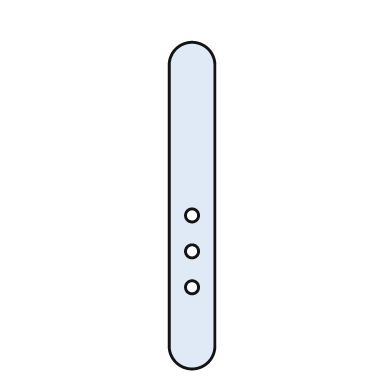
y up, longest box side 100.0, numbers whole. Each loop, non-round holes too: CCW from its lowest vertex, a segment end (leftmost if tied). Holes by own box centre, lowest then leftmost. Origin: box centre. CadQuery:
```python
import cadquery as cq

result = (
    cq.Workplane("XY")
    .moveTo(-7.0, -43.0)
    .threePointArc((0.0, -50.0), (7.0, -43.0))
    .lineTo(7.0, 43.0)
    .threePointArc((0.0, 50.0), (-7.0, 43.0))
    .close()
    .moveTo(0.0, -25.0)
    .circle(2.0)
    .moveTo(0.0, -14.0)
    .circle(2.0)
    .moveTo(0.0, -3.0)
    .circle(2.0)
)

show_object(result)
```